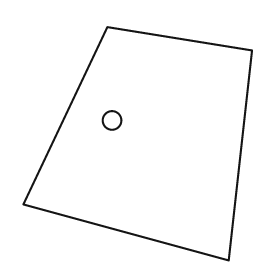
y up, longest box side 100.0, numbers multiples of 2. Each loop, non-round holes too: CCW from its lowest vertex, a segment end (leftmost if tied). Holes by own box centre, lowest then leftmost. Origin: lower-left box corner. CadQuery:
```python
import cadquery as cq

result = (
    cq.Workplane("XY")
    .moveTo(88.0, 0.0)
    .lineTo(98.0, 90.0)
    .lineTo(36.0, 100.0)
    .lineTo(0.0, 24.0)
    .close()
    .moveTo(38.0, 60.0)
    .circle(4.0)
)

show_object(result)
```